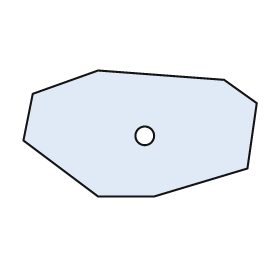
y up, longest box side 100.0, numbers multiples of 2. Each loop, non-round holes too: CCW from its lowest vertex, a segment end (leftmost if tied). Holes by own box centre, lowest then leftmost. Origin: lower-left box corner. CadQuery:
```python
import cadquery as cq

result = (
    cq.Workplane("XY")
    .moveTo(32.0, 0.0)
    .lineTo(56.0, 0.0)
    .lineTo(96.0, 12.0)
    .lineTo(100.0, 40.0)
    .lineTo(86.0, 50.0)
    .lineTo(32.0, 54.0)
    .lineTo(4.0, 44.0)
    .lineTo(0.0, 24.0)
    .close()
    .moveTo(52.0, 26.0)
    .circle(4.0)
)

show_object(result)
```